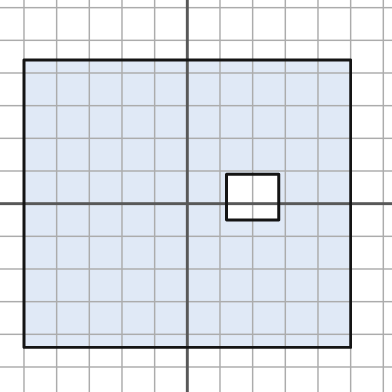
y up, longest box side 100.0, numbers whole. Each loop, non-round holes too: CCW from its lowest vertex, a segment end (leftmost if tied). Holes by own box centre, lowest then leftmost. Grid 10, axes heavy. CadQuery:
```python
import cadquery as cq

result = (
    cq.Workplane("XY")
    .moveTo(-50.0, -44.0)
    .lineTo(50.0, -44.0)
    .lineTo(50.0, 44.0)
    .lineTo(-50.0, 44.0)
    .close()
    .moveTo(12.0, -5.0)
    .lineTo(28.0, -5.0)
    .lineTo(28.0, 9.0)
    .lineTo(12.0, 9.0)
    .close()
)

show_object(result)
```